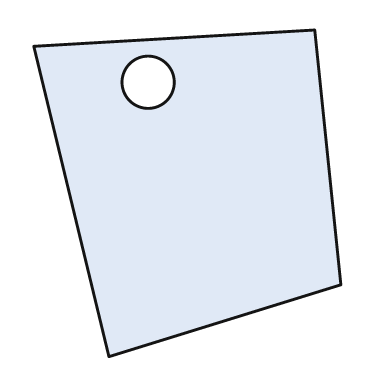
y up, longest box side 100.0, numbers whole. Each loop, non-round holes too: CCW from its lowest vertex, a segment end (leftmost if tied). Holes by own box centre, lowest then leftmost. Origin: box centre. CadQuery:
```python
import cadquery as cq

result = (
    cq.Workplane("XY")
    .moveTo(-24.0, -50.0)
    .lineTo(47.0, -28.0)
    .lineTo(39.0, 50.0)
    .lineTo(-47.0, 45.0)
    .close()
    .moveTo(-12.0, 34.0)
    .circle(8.0)
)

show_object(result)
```